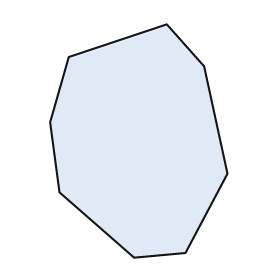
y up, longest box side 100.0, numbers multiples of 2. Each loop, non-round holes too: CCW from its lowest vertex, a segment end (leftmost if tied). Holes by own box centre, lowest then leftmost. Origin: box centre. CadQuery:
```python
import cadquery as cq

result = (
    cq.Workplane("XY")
    .moveTo(-2.0, -50.0)
    .lineTo(20.0, -48.0)
    .lineTo(38.0, -14.0)
    .lineTo(28.0, 32.0)
    .lineTo(12.0, 50.0)
    .lineTo(-30.0, 36.0)
    .lineTo(-38.0, 8.0)
    .lineTo(-34.0, -22.0)
    .close()
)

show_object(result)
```